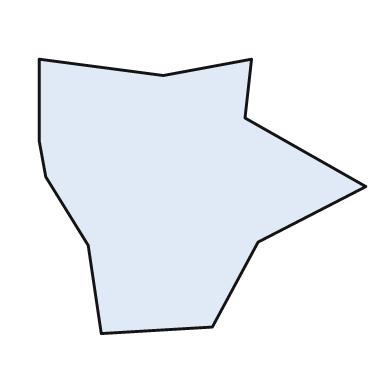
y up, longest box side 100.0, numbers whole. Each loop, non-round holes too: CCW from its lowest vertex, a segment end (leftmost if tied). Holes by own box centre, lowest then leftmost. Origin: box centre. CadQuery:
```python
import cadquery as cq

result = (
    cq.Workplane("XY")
    .moveTo(-31.0, -42.0)
    .lineTo(3.0, -40.0)
    .lineTo(17.0, -14.0)
    .lineTo(50.0, 3.0)
    .lineTo(13.0, 24.0)
    .lineTo(15.0, 42.0)
    .lineTo(-12.0, 37.0)
    .lineTo(-50.0, 42.0)
    .lineTo(-50.0, 17.0)
    .lineTo(-48.0, 6.0)
    .lineTo(-35.0, -15.0)
    .close()
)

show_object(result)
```